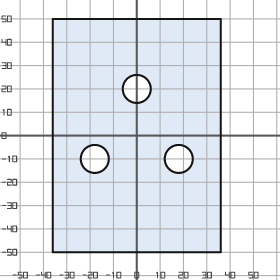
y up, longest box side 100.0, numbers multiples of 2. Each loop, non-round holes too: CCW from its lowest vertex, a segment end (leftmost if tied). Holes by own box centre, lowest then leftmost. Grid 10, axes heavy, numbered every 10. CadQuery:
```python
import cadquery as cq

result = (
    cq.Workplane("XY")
    .moveTo(-36.0, -50.0)
    .lineTo(36.0, -50.0)
    .lineTo(36.0, 50.0)
    .lineTo(-36.0, 50.0)
    .close()
    .moveTo(-18.0, -10.0)
    .circle(6.0)
    .moveTo(18.0, -10.0)
    .circle(6.0)
    .moveTo(0.0, 20.0)
    .circle(6.0)
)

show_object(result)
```